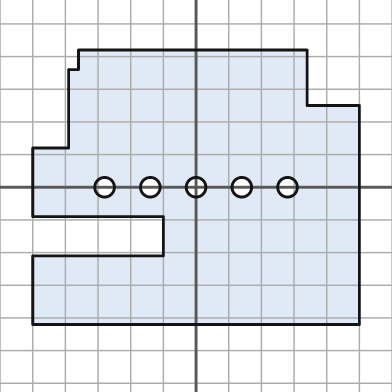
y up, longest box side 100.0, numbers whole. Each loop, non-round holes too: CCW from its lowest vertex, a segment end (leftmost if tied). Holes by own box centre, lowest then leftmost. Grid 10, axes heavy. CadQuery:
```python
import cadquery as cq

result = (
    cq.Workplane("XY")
    .moveTo(-50.0, -42.0)
    .lineTo(50.0, -42.0)
    .lineTo(50.0, 25.0)
    .lineTo(34.0, 25.0)
    .lineTo(34.0, 42.0)
    .lineTo(-36.0, 42.0)
    .lineTo(-36.0, 36.0)
    .lineTo(-39.0, 36.0)
    .lineTo(-39.0, 12.0)
    .lineTo(-50.0, 12.0)
    .lineTo(-50.0, -9.0)
    .lineTo(-10.0, -9.0)
    .lineTo(-10.0, -21.0)
    .lineTo(-50.0, -21.0)
    .close()
    .moveTo(-28.0, 0.0)
    .circle(3.0)
    .moveTo(-14.0, 0.0)
    .circle(3.0)
    .moveTo(0.0, 0.0)
    .circle(3.0)
    .moveTo(14.0, 0.0)
    .circle(3.0)
    .moveTo(28.0, 0.0)
    .circle(3.0)
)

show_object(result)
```